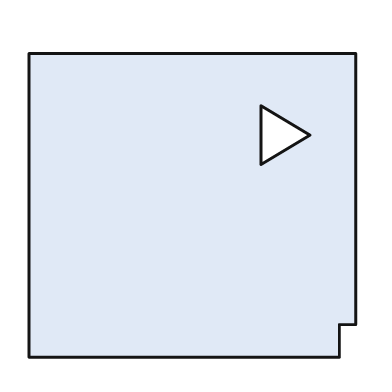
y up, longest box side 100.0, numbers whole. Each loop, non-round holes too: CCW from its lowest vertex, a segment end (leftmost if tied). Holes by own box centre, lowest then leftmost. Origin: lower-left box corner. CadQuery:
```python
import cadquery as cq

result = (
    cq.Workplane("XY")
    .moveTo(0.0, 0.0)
    .lineTo(95.0, 0.0)
    .lineTo(95.0, 10.0)
    .lineTo(100.0, 10.0)
    .lineTo(100.0, 93.0)
    .lineTo(0.0, 93.0)
    .close()
    .moveTo(71.0, 59.0)
    .lineTo(86.0, 68.0)
    .lineTo(71.0, 77.0)
    .close()
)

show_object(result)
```